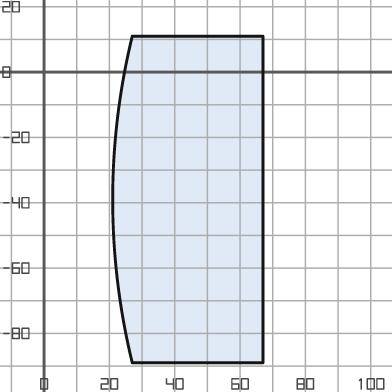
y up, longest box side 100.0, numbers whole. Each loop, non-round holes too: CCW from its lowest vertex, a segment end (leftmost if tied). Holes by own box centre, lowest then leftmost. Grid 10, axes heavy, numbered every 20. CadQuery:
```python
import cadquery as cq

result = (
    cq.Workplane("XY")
    .moveTo(27.0, -89.0)
    .lineTo(67.0, -89.0)
    .lineTo(67.0, 11.0)
    .lineTo(27.0, 11.0)
    .threePointArc((21.0, -39.0), (27.0, -89.0))
    .close()
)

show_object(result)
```